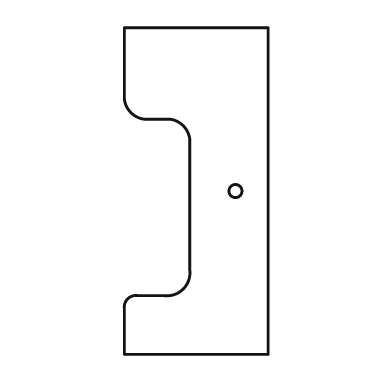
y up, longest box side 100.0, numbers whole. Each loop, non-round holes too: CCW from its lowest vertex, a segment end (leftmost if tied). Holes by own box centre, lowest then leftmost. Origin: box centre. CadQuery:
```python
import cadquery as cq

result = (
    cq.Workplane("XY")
    .moveTo(-22.0, -50.0)
    .lineTo(22.0, -50.0)
    .lineTo(22.0, 50.0)
    .lineTo(-22.0, 50.0)
    .lineTo(-22.0, 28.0)
    .threePointArc((-20.0, 24.0), (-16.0, 22.0))
    .lineTo(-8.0, 22.0)
    .threePointArc((-4.0, 20.0), (-2.0, 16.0))
    .lineTo(-2.0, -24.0)
    .threePointArc((-4.0, -30.0), (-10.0, -32.0))
    .lineTo(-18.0, -32.0)
    .threePointArc((-21.0, -33.0), (-22.0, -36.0))
    .close()
    .moveTo(12.0, 0.0)
    .circle(2.0)
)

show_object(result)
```